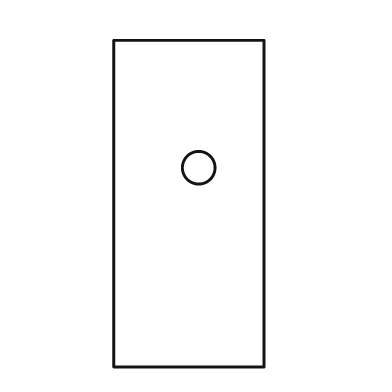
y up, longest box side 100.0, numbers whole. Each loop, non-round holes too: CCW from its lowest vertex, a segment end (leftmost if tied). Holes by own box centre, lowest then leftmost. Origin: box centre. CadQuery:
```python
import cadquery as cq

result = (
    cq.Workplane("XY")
    .moveTo(-23.0, -50.0)
    .lineTo(23.0, -50.0)
    .lineTo(23.0, 50.0)
    .lineTo(-23.0, 50.0)
    .close()
    .moveTo(3.0, 11.0)
    .circle(5.0)
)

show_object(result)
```